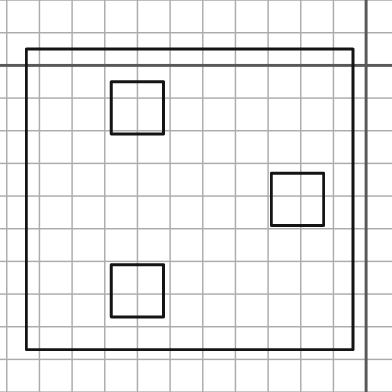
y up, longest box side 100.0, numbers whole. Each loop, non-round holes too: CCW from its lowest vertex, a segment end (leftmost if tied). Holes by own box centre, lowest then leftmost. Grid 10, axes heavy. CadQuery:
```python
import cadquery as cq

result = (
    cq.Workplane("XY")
    .moveTo(-104.0, -87.0)
    .lineTo(-4.0, -87.0)
    .lineTo(-4.0, 5.0)
    .lineTo(-104.0, 5.0)
    .close()
    .moveTo(-78.0, -77.0)
    .lineTo(-62.0, -77.0)
    .lineTo(-62.0, -61.0)
    .lineTo(-78.0, -61.0)
    .close()
    .moveTo(-29.0, -49.0)
    .lineTo(-13.0, -49.0)
    .lineTo(-13.0, -33.0)
    .lineTo(-29.0, -33.0)
    .close()
    .moveTo(-78.0, -21.0)
    .lineTo(-62.0, -21.0)
    .lineTo(-62.0, -5.0)
    .lineTo(-78.0, -5.0)
    .close()
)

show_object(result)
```